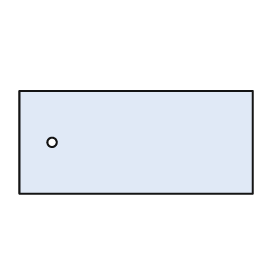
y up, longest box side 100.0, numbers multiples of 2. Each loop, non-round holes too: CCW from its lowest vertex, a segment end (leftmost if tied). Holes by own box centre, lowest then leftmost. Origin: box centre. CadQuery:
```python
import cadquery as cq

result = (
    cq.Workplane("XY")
    .moveTo(-50.0, -22.0)
    .lineTo(50.0, -22.0)
    .lineTo(50.0, 22.0)
    .lineTo(-50.0, 22.0)
    .close()
    .moveTo(-36.0, 0.0)
    .circle(2.0)
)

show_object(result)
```